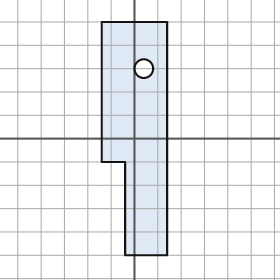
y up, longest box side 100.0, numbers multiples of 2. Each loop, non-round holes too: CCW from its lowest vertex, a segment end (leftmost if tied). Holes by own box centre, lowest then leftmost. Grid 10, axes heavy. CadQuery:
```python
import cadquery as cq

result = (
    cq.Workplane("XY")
    .moveTo(-4.0, -50.0)
    .lineTo(14.0, -50.0)
    .lineTo(14.0, 50.0)
    .lineTo(-14.0, 50.0)
    .lineTo(-14.0, -10.0)
    .lineTo(-4.0, -10.0)
    .close()
    .moveTo(4.0, 30.0)
    .circle(4.0)
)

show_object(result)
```